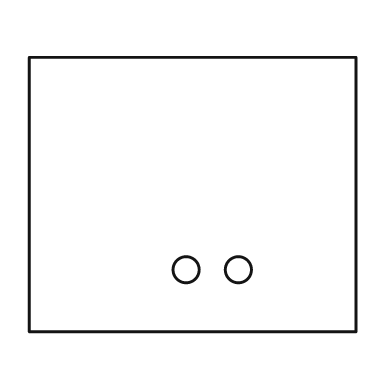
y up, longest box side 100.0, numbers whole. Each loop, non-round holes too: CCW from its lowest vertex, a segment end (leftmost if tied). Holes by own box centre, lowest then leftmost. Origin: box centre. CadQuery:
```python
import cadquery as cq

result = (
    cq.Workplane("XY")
    .moveTo(-50.0, -42.0)
    .lineTo(50.0, -42.0)
    .lineTo(50.0, 42.0)
    .lineTo(-50.0, 42.0)
    .close()
    .moveTo(-2.0, -23.0)
    .circle(4.0)
    .moveTo(14.0, -23.0)
    .circle(4.0)
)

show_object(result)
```